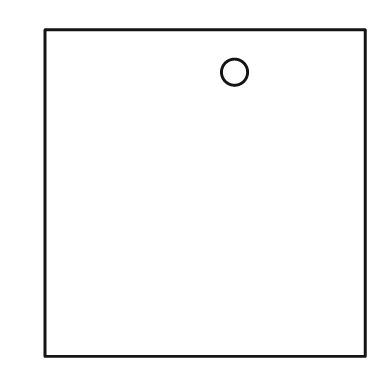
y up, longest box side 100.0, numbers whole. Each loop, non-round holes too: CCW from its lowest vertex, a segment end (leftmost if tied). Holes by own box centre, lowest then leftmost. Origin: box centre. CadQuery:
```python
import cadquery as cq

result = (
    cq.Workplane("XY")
    .moveTo(-49.0, -50.0)
    .lineTo(49.0, -50.0)
    .lineTo(49.0, 50.0)
    .lineTo(-49.0, 50.0)
    .close()
    .moveTo(9.0, 37.0)
    .circle(4.0)
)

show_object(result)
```